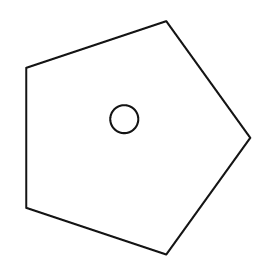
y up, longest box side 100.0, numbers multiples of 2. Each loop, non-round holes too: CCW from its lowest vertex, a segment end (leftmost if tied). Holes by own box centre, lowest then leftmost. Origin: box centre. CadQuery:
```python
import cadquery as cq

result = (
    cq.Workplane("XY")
    .moveTo(12.0, -50.0)
    .lineTo(48.0, 0.0)
    .lineTo(12.0, 50.0)
    .lineTo(-48.0, 30.0)
    .lineTo(-48.0, -30.0)
    .close()
    .moveTo(-6.0, 8.0)
    .circle(6.0)
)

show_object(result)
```